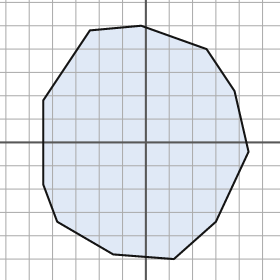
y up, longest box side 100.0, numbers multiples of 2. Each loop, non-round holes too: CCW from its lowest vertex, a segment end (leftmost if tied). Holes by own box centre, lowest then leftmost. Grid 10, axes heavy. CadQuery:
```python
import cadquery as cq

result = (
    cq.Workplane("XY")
    .moveTo(12.0, -50.0)
    .lineTo(30.0, -34.0)
    .lineTo(44.0, -4.0)
    .lineTo(38.0, 22.0)
    .lineTo(26.0, 40.0)
    .lineTo(-2.0, 50.0)
    .lineTo(-24.0, 48.0)
    .lineTo(-44.0, 18.0)
    .lineTo(-44.0, -18.0)
    .lineTo(-38.0, -34.0)
    .lineTo(-14.0, -48.0)
    .close()
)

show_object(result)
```